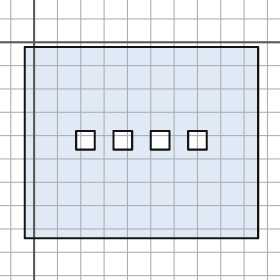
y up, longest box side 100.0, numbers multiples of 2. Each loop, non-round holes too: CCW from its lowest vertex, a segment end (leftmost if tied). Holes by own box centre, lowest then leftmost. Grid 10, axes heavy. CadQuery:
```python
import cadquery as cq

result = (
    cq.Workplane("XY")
    .moveTo(-4.0, -84.0)
    .lineTo(96.0, -84.0)
    .lineTo(96.0, -2.0)
    .lineTo(-4.0, -2.0)
    .close()
    .moveTo(18.0, -46.0)
    .lineTo(26.0, -46.0)
    .lineTo(26.0, -38.0)
    .lineTo(18.0, -38.0)
    .close()
    .moveTo(34.0, -46.0)
    .lineTo(42.0, -46.0)
    .lineTo(42.0, -38.0)
    .lineTo(34.0, -38.0)
    .close()
    .moveTo(50.0, -46.0)
    .lineTo(58.0, -46.0)
    .lineTo(58.0, -38.0)
    .lineTo(50.0, -38.0)
    .close()
    .moveTo(66.0, -46.0)
    .lineTo(74.0, -46.0)
    .lineTo(74.0, -38.0)
    .lineTo(66.0, -38.0)
    .close()
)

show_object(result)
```